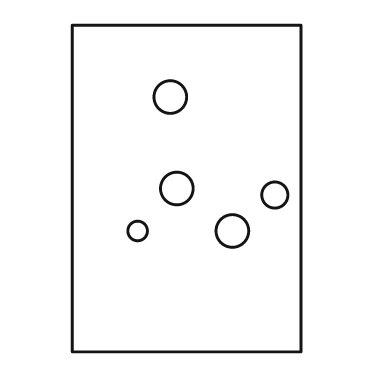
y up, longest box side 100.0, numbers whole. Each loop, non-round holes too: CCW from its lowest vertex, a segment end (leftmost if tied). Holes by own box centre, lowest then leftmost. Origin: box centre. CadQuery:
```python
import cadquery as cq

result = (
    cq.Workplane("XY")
    .moveTo(-35.0, -50.0)
    .lineTo(35.0, -50.0)
    .lineTo(35.0, 50.0)
    .lineTo(-35.0, 50.0)
    .close()
    .moveTo(-15.0, -13.0)
    .circle(3.0)
    .moveTo(14.0, -13.0)
    .circle(5.0)
    .moveTo(27.0, -2.0)
    .circle(4.0)
    .moveTo(-3.0, 0.0)
    .circle(5.0)
    .moveTo(-5.0, 28.0)
    .circle(5.0)
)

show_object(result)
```